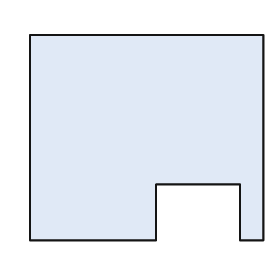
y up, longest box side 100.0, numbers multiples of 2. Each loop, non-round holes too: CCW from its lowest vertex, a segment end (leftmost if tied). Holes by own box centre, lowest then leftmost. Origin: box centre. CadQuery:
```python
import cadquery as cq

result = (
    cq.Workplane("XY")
    .moveTo(-50.0, -44.0)
    .lineTo(4.0, -44.0)
    .lineTo(4.0, -20.0)
    .lineTo(40.0, -20.0)
    .lineTo(40.0, -44.0)
    .lineTo(50.0, -44.0)
    .lineTo(50.0, 44.0)
    .lineTo(-50.0, 44.0)
    .close()
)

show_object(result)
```